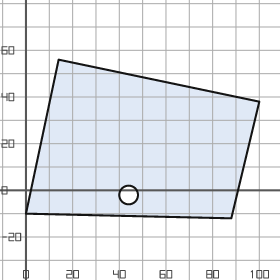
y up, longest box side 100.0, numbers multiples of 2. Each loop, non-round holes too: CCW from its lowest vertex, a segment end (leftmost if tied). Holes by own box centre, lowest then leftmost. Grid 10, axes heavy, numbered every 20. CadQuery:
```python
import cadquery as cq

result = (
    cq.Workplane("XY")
    .moveTo(88.0, -12.0)
    .lineTo(100.0, 38.0)
    .lineTo(14.0, 56.0)
    .lineTo(0.0, -10.0)
    .close()
    .moveTo(44.0, -2.0)
    .circle(4.0)
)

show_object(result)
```